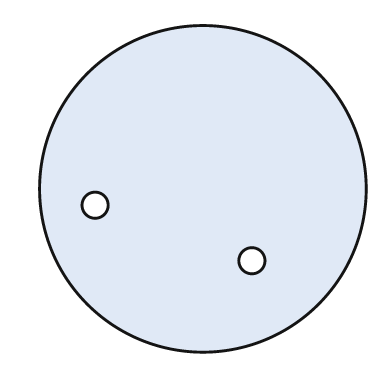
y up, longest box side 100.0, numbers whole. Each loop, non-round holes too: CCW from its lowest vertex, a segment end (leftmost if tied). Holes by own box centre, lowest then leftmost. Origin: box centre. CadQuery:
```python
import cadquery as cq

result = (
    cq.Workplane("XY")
    .moveTo(0.0, 0.0)
    .circle(50.0)
    .moveTo(15.0, -22.0)
    .circle(4.0)
    .moveTo(-33.0, -5.0)
    .circle(4.0)
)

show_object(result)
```